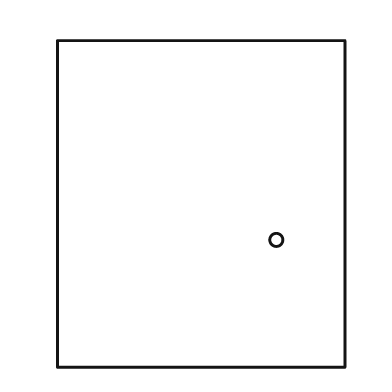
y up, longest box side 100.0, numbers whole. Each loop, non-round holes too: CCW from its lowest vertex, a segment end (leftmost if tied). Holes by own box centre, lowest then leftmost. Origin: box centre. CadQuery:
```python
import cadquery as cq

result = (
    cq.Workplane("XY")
    .moveTo(-44.0, -50.0)
    .lineTo(44.0, -50.0)
    .lineTo(44.0, 50.0)
    .lineTo(-44.0, 50.0)
    .close()
    .moveTo(23.0, -11.0)
    .circle(2.0)
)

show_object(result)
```